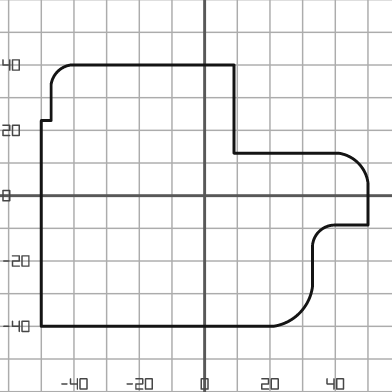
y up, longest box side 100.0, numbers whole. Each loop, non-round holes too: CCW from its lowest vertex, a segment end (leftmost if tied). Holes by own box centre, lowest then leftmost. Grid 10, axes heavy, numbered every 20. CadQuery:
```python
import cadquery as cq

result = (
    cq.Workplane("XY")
    .moveTo(-50.0, -40.0)
    .lineTo(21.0, -40.0)
    .threePointArc((29.0, -36.0), (33.0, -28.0))
    .lineTo(33.0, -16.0)
    .threePointArc((35.0, -11.0), (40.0, -9.0))
    .lineTo(50.0, -9.0)
    .lineTo(50.0, 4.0)
    .threePointArc((47.0, 10.0), (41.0, 13.0))
    .lineTo(9.0, 13.0)
    .lineTo(9.0, 40.0)
    .lineTo(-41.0, 40.0)
    .threePointArc((-45.0, 38.0), (-47.0, 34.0))
    .lineTo(-47.0, 23.0)
    .lineTo(-50.0, 23.0)
    .close()
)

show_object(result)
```